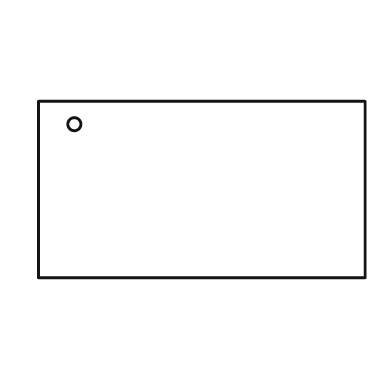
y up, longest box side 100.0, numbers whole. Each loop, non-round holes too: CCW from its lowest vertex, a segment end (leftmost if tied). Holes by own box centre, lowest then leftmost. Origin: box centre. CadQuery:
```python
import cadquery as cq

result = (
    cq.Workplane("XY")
    .moveTo(-50.0, -27.0)
    .lineTo(50.0, -27.0)
    .lineTo(50.0, 27.0)
    .lineTo(-50.0, 27.0)
    .close()
    .moveTo(-39.0, 20.0)
    .circle(2.0)
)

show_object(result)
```